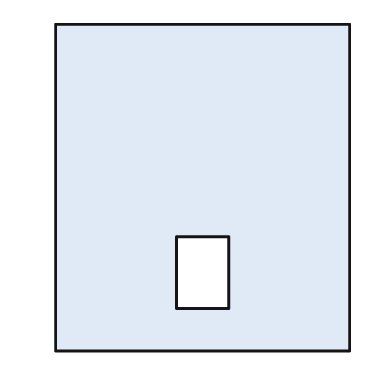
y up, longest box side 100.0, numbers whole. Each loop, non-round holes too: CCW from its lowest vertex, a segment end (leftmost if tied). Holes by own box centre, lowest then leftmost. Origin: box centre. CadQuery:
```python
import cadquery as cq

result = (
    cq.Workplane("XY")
    .moveTo(-45.0, -50.0)
    .lineTo(45.0, -50.0)
    .lineTo(45.0, 50.0)
    .lineTo(-45.0, 50.0)
    .close()
    .moveTo(-8.0, -37.0)
    .lineTo(8.0, -37.0)
    .lineTo(8.0, -15.0)
    .lineTo(-8.0, -15.0)
    .close()
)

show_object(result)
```